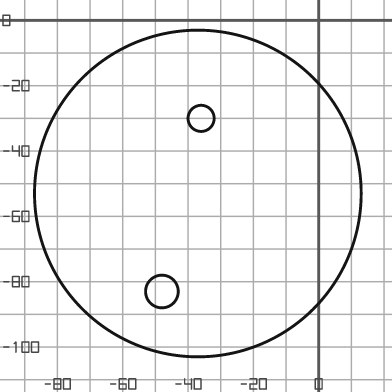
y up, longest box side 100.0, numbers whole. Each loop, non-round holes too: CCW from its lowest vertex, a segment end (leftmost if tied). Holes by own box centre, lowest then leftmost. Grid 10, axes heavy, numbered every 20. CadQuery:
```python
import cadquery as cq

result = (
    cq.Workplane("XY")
    .moveTo(-37.0, -53.0)
    .circle(50.0)
    .moveTo(-48.0, -83.0)
    .circle(5.0)
    .moveTo(-36.0, -30.0)
    .circle(4.0)
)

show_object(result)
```